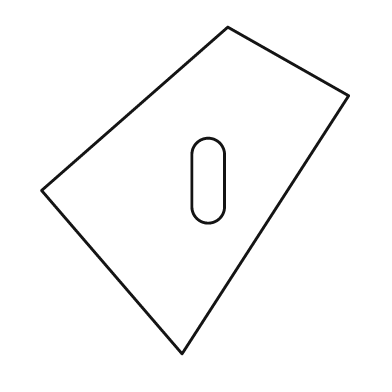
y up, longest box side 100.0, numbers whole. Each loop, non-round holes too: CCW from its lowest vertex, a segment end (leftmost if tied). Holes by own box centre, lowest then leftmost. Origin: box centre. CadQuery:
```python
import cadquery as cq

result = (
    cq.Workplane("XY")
    .moveTo(-4.0, -50.0)
    .lineTo(47.0, 29.0)
    .lineTo(10.0, 50.0)
    .lineTo(-47.0, 0.0)
    .close()
    .moveTo(-1.0, -5.0)
    .threePointArc((4.0, -10.0), (9.0, -5.0))
    .lineTo(9.0, 11.0)
    .threePointArc((4.0, 16.0), (-1.0, 11.0))
    .close()
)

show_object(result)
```